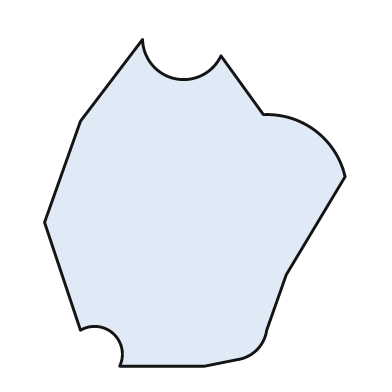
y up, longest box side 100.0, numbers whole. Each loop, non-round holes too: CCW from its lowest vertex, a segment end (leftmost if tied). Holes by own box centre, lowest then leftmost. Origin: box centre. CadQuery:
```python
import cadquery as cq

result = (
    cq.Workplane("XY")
    .moveTo(-23.0, -50.0)
    .lineTo(3.0, -50.0)
    .lineTo(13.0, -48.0)
    .threePointArc((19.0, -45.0), (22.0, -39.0))
    .lineTo(28.0, -22.0)
    .lineTo(46.0, 8.0)
    .threePointArc((37.0, 22.0), (21.0, 27.0))
    .lineTo(8.0, 45.0)
    .threePointArc((-6.0, 38.0), (-16.0, 50.0))
    .lineTo(-35.0, 25.0)
    .lineTo(-46.0, -6.0)
    .lineTo(-35.0, -39.0)
    .threePointArc((-25.0, -40.0), (-23.0, -50.0))
    .close()
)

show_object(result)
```